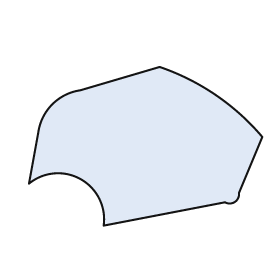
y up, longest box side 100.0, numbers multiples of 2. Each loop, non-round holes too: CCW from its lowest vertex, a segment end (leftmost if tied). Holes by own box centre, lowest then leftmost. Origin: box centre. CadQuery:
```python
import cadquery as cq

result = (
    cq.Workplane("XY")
    .moveTo(-18.0, -34.0)
    .lineTo(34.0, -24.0)
    .threePointArc((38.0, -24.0), (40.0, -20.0))
    .lineTo(50.0, 4.0)
    .threePointArc((30.0, 22.0), (6.0, 34.0))
    .lineTo(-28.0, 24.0)
    .threePointArc((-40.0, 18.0), (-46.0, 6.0))
    .lineTo(-50.0, -16.0)
    .threePointArc((-28.0, -14.0), (-18.0, -34.0))
    .close()
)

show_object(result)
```